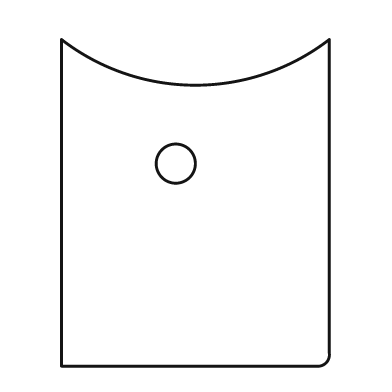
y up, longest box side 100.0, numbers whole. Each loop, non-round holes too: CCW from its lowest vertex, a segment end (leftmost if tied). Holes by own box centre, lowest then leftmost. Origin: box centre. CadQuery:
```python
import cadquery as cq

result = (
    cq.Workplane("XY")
    .moveTo(-41.0, -50.0)
    .lineTo(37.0, -50.0)
    .threePointArc((40.0, -49.0), (41.0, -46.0))
    .lineTo(41.0, 50.0)
    .threePointArc((0.0, 36.0), (-41.0, 50.0))
    .close()
    .moveTo(-6.0, 12.0)
    .circle(6.0)
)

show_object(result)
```